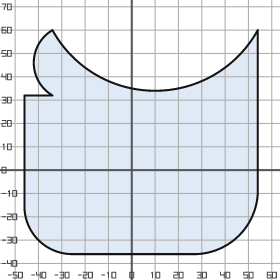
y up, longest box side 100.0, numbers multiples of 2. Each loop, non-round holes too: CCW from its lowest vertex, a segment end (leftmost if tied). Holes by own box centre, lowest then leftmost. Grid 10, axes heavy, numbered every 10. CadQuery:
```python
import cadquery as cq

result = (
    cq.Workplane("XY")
    .moveTo(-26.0, -36.0)
    .lineTo(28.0, -36.0)
    .threePointArc((46.0, -28.0), (54.0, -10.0))
    .lineTo(54.0, 60.0)
    .threePointArc((10.0, 34.0), (-34.0, 60.0))
    .threePointArc((-42.0, 46.0), (-34.0, 32.0))
    .lineTo(-46.0, 32.0)
    .lineTo(-46.0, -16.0)
    .threePointArc((-40.0, -30.0), (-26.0, -36.0))
    .close()
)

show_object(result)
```